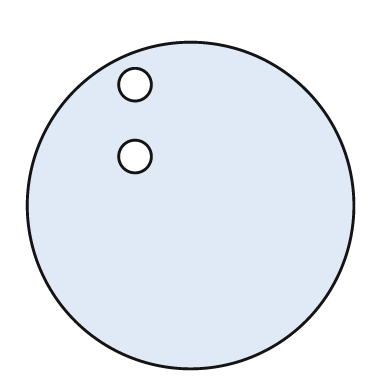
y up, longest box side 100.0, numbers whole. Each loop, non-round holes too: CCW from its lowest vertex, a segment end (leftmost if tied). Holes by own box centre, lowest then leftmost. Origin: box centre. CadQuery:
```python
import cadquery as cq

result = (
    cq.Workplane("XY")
    .moveTo(0.0, 0.0)
    .circle(50.0)
    .moveTo(-17.0, 15.0)
    .circle(5.0)
    .moveTo(-17.0, 37.0)
    .circle(5.0)
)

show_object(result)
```